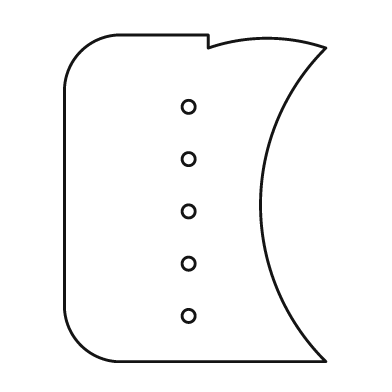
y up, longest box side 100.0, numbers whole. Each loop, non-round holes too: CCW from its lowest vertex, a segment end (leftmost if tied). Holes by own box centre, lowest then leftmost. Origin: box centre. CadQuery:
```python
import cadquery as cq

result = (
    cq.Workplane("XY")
    .moveTo(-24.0, -50.0)
    .lineTo(40.0, -50.0)
    .threePointArc((20.0, -2.0), (40.0, 46.0))
    .threePointArc((22.0, 49.0), (4.0, 46.0))
    .lineTo(4.0, 50.0)
    .lineTo(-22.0, 50.0)
    .threePointArc((-35.0, 45.0), (-40.0, 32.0))
    .lineTo(-40.0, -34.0)
    .threePointArc((-35.0, -45.0), (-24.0, -50.0))
    .close()
    .moveTo(-2.0, -36.0)
    .circle(2.0)
    .moveTo(-2.0, -20.0)
    .circle(2.0)
    .moveTo(-2.0, -4.0)
    .circle(2.0)
    .moveTo(-2.0, 12.0)
    .circle(2.0)
    .moveTo(-2.0, 28.0)
    .circle(2.0)
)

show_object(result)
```